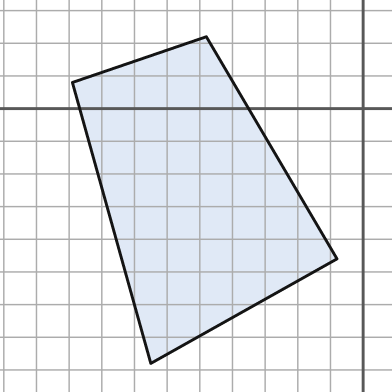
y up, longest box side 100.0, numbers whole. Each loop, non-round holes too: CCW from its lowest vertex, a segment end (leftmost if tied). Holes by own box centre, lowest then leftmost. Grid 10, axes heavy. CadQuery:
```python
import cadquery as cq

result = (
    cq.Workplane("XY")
    .moveTo(-65.0, -78.0)
    .lineTo(-8.0, -46.0)
    .lineTo(-48.0, 22.0)
    .lineTo(-89.0, 8.0)
    .close()
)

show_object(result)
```